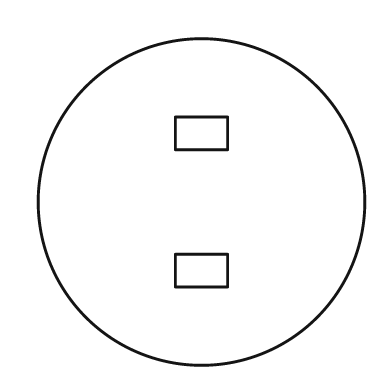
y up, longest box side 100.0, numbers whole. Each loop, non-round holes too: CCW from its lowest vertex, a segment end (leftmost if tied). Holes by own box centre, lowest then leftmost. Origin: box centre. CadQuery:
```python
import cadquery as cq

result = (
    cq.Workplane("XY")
    .moveTo(0.0, 0.0)
    .circle(50.0)
    .moveTo(-8.0, -26.0)
    .lineTo(8.0, -26.0)
    .lineTo(8.0, -16.0)
    .lineTo(-8.0, -16.0)
    .close()
    .moveTo(-8.0, 16.0)
    .lineTo(8.0, 16.0)
    .lineTo(8.0, 26.0)
    .lineTo(-8.0, 26.0)
    .close()
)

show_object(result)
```